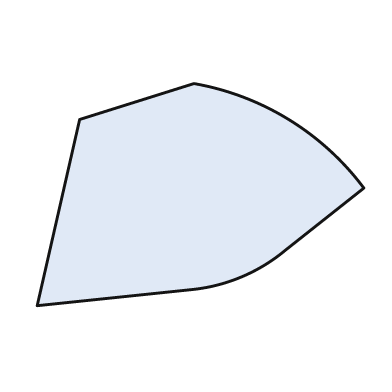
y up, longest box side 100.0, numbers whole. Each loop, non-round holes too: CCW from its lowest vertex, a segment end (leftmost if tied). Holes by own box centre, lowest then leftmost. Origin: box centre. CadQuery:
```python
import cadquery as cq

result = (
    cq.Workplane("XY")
    .moveTo(-50.0, -34.0)
    .lineTo(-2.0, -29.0)
    .threePointArc((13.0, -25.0), (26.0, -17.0))
    .lineTo(50.0, 2.0)
    .threePointArc((27.0, 23.0), (-2.0, 34.0))
    .lineTo(-37.0, 23.0)
    .close()
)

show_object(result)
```